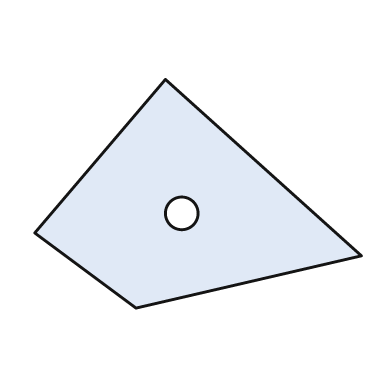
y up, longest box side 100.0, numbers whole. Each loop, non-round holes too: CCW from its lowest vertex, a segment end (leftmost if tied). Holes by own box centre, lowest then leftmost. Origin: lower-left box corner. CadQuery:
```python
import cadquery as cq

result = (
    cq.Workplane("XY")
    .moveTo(31.0, 0.0)
    .lineTo(100.0, 16.0)
    .lineTo(40.0, 70.0)
    .lineTo(0.0, 23.0)
    .close()
    .moveTo(45.0, 29.0)
    .circle(5.0)
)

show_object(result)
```